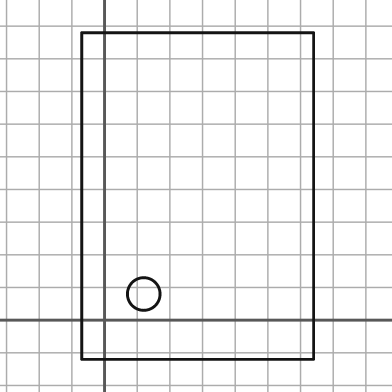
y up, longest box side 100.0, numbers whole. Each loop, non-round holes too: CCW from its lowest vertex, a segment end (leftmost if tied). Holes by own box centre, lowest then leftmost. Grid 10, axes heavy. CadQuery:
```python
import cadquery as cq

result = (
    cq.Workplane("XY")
    .moveTo(-7.0, -12.0)
    .lineTo(64.0, -12.0)
    .lineTo(64.0, 88.0)
    .lineTo(-7.0, 88.0)
    .close()
    .moveTo(12.0, 8.0)
    .circle(5.0)
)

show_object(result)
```